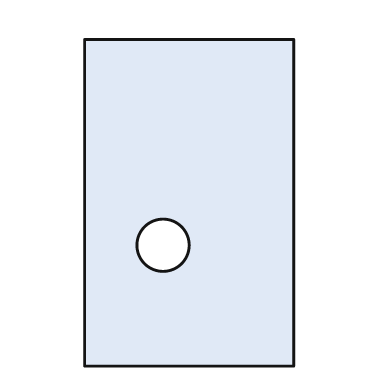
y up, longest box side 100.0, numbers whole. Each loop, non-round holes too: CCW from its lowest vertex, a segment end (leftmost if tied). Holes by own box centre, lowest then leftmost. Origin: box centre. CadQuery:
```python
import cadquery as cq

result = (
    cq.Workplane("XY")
    .moveTo(-32.0, -50.0)
    .lineTo(32.0, -50.0)
    .lineTo(32.0, 50.0)
    .lineTo(-32.0, 50.0)
    .close()
    .moveTo(-8.0, -13.0)
    .circle(8.0)
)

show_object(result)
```